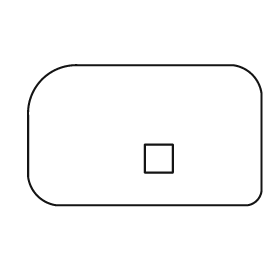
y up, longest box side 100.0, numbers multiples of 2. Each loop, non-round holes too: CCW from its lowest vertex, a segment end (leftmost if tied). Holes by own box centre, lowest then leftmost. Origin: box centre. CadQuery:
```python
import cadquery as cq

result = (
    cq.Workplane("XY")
    .moveTo(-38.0, -30.0)
    .lineTo(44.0, -30.0)
    .threePointArc((48.0, -28.0), (50.0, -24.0))
    .lineTo(50.0, 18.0)
    .threePointArc((46.0, 26.0), (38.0, 30.0))
    .lineTo(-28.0, 30.0)
    .threePointArc((-44.0, 24.0), (-50.0, 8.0))
    .lineTo(-50.0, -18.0)
    .threePointArc((-46.0, -26.0), (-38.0, -30.0))
    .close()
    .moveTo(0.0, -16.0)
    .lineTo(12.0, -16.0)
    .lineTo(12.0, -4.0)
    .lineTo(0.0, -4.0)
    .close()
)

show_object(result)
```